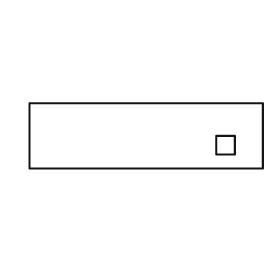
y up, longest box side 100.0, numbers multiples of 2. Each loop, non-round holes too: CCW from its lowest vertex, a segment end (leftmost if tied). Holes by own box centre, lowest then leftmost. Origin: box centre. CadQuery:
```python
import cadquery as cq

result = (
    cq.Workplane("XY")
    .moveTo(-50.0, -14.0)
    .lineTo(50.0, -14.0)
    .lineTo(50.0, 14.0)
    .lineTo(-50.0, 14.0)
    .close()
    .moveTo(30.0, -8.0)
    .lineTo(38.0, -8.0)
    .lineTo(38.0, 0.0)
    .lineTo(30.0, 0.0)
    .close()
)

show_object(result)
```